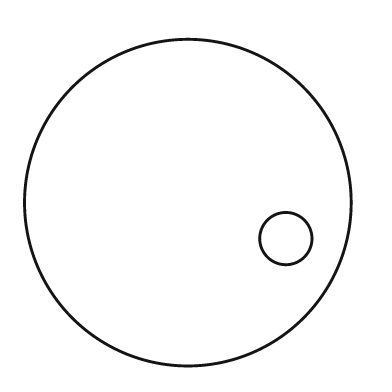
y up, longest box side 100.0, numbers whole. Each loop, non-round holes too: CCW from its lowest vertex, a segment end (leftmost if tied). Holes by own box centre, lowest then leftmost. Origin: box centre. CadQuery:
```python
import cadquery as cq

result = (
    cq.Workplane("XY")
    .moveTo(0.0, 0.0)
    .circle(50.0)
    .moveTo(30.0, -11.0)
    .circle(8.0)
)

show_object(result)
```